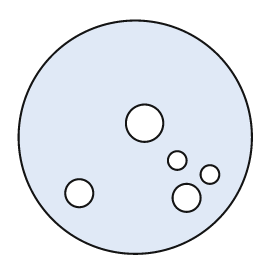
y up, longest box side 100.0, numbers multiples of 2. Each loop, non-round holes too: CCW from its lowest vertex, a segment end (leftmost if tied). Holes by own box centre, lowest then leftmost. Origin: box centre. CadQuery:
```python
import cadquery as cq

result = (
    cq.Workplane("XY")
    .moveTo(0.0, 0.0)
    .circle(50.0)
    .moveTo(22.0, -26.0)
    .circle(6.0)
    .moveTo(-24.0, -24.0)
    .circle(6.0)
    .moveTo(32.0, -16.0)
    .circle(4.0)
    .moveTo(18.0, -10.0)
    .circle(4.0)
    .moveTo(4.0, 6.0)
    .circle(8.0)
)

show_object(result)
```